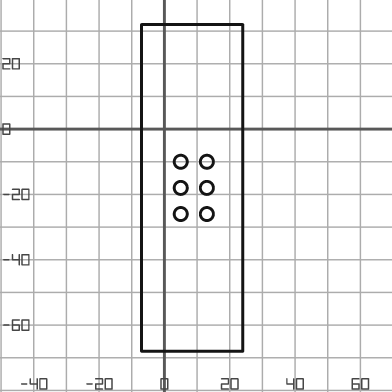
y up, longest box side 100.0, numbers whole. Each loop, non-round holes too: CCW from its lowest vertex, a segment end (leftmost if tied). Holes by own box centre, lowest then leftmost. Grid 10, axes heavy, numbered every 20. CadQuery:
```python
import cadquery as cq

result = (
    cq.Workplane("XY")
    .moveTo(-7.0, -68.0)
    .lineTo(24.0, -68.0)
    .lineTo(24.0, 32.0)
    .lineTo(-7.0, 32.0)
    .close()
    .moveTo(5.0, -26.0)
    .circle(2.0)
    .moveTo(13.0, -26.0)
    .circle(2.0)
    .moveTo(5.0, -18.0)
    .circle(2.0)
    .moveTo(13.0, -18.0)
    .circle(2.0)
    .moveTo(5.0, -10.0)
    .circle(2.0)
    .moveTo(13.0, -10.0)
    .circle(2.0)
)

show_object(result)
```